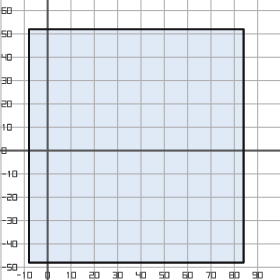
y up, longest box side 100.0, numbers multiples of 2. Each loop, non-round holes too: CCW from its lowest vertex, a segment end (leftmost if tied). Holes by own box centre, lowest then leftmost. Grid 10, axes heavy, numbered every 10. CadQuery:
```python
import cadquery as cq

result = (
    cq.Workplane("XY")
    .moveTo(-8.0, -48.0)
    .lineTo(84.0, -48.0)
    .lineTo(84.0, 52.0)
    .lineTo(-8.0, 52.0)
    .close()
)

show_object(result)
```